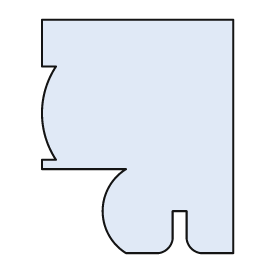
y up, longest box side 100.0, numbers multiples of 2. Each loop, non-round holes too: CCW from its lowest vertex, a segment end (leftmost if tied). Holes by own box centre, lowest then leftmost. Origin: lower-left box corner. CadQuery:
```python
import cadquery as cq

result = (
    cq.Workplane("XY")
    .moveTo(36.0, 0.0)
    .lineTo(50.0, 0.0)
    .threePointArc((54.0, 2.0), (56.0, 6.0))
    .lineTo(56.0, 18.0)
    .lineTo(62.0, 18.0)
    .lineTo(62.0, 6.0)
    .threePointArc((64.0, 2.0), (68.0, 0.0))
    .lineTo(82.0, 0.0)
    .lineTo(82.0, 100.0)
    .lineTo(0.0, 100.0)
    .lineTo(0.0, 80.0)
    .lineTo(6.0, 80.0)
    .threePointArc((0.0, 60.0), (6.0, 40.0))
    .lineTo(0.0, 40.0)
    .lineTo(0.0, 36.0)
    .lineTo(36.0, 36.0)
    .threePointArc((26.0, 18.0), (36.0, 0.0))
    .close()
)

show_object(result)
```